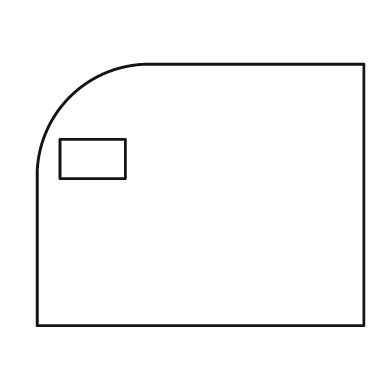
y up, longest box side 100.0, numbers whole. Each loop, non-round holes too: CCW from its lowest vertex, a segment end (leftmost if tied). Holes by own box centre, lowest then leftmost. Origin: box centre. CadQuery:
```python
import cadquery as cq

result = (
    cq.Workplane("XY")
    .moveTo(-50.0, -40.0)
    .lineTo(50.0, -40.0)
    .lineTo(50.0, 40.0)
    .lineTo(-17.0, 40.0)
    .threePointArc((-40.0, 30.0), (-50.0, 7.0))
    .close()
    .moveTo(-43.0, 5.0)
    .lineTo(-23.0, 5.0)
    .lineTo(-23.0, 17.0)
    .lineTo(-43.0, 17.0)
    .close()
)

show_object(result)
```